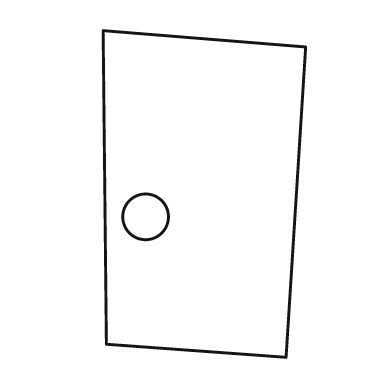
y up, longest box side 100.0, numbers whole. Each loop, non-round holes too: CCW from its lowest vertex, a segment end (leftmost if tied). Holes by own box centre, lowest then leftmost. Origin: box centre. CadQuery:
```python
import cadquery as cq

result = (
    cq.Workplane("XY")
    .moveTo(25.0, -50.0)
    .lineTo(31.0, 45.0)
    .lineTo(-31.0, 50.0)
    .lineTo(-30.0, -46.0)
    .close()
    .moveTo(-18.0, -7.0)
    .circle(7.0)
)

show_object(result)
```